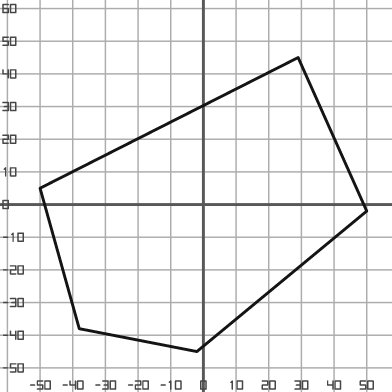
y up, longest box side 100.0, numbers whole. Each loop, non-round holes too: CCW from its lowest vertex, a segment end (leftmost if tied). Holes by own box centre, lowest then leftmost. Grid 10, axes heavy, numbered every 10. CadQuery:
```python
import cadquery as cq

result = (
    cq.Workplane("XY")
    .moveTo(-2.0, -45.0)
    .lineTo(50.0, -2.0)
    .lineTo(29.0, 45.0)
    .lineTo(-50.0, 5.0)
    .lineTo(-38.0, -38.0)
    .close()
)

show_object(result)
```